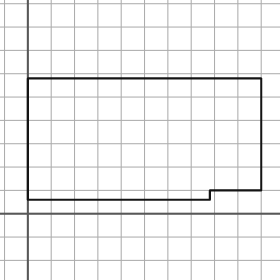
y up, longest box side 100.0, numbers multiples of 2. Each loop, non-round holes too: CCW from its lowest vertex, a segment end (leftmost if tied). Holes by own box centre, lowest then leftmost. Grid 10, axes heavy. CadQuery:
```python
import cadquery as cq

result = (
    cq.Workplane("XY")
    .moveTo(0.0, 6.0)
    .lineTo(78.0, 6.0)
    .lineTo(78.0, 10.0)
    .lineTo(100.0, 10.0)
    .lineTo(100.0, 58.0)
    .lineTo(0.0, 58.0)
    .close()
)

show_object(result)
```